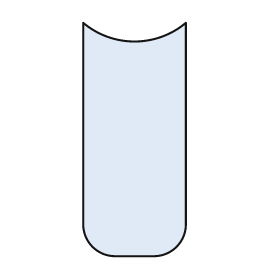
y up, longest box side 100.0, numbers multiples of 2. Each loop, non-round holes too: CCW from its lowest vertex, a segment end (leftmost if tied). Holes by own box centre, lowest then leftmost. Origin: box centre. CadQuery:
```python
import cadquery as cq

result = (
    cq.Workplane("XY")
    .moveTo(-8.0, -50.0)
    .lineTo(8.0, -50.0)
    .threePointArc((18.0, -46.0), (22.0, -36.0))
    .lineTo(22.0, 50.0)
    .threePointArc((0.0, 42.0), (-22.0, 50.0))
    .lineTo(-22.0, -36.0)
    .threePointArc((-18.0, -46.0), (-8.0, -50.0))
    .close()
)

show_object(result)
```